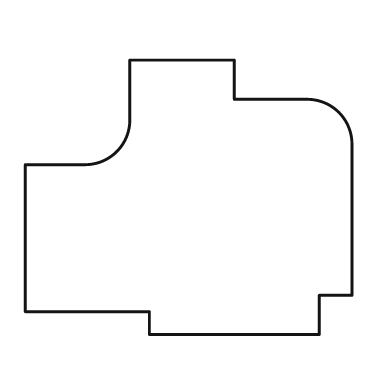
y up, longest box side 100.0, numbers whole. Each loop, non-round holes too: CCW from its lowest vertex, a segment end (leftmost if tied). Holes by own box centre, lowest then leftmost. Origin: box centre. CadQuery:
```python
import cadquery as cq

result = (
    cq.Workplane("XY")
    .moveTo(-12.0, -42.0)
    .lineTo(40.0, -42.0)
    .lineTo(40.0, -30.0)
    .lineTo(50.0, -30.0)
    .lineTo(50.0, 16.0)
    .threePointArc((46.0, 26.0), (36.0, 30.0))
    .lineTo(14.0, 30.0)
    .lineTo(14.0, 42.0)
    .lineTo(-18.0, 42.0)
    .lineTo(-18.0, 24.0)
    .threePointArc((-22.0, 14.0), (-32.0, 10.0))
    .lineTo(-50.0, 10.0)
    .lineTo(-50.0, -35.0)
    .lineTo(-12.0, -35.0)
    .close()
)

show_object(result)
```